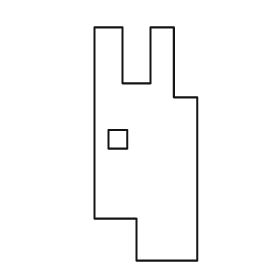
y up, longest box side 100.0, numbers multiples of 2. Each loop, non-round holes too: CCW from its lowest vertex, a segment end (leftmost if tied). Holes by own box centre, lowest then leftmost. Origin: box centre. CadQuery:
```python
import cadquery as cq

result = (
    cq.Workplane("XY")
    .moveTo(-4.0, -50.0)
    .lineTo(22.0, -50.0)
    .lineTo(22.0, 20.0)
    .lineTo(12.0, 20.0)
    .lineTo(12.0, 50.0)
    .lineTo(2.0, 50.0)
    .lineTo(2.0, 26.0)
    .lineTo(-10.0, 26.0)
    .lineTo(-10.0, 50.0)
    .lineTo(-22.0, 50.0)
    .lineTo(-22.0, -32.0)
    .lineTo(-4.0, -32.0)
    .close()
    .moveTo(-16.0, -2.0)
    .lineTo(-8.0, -2.0)
    .lineTo(-8.0, 6.0)
    .lineTo(-16.0, 6.0)
    .close()
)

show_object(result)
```